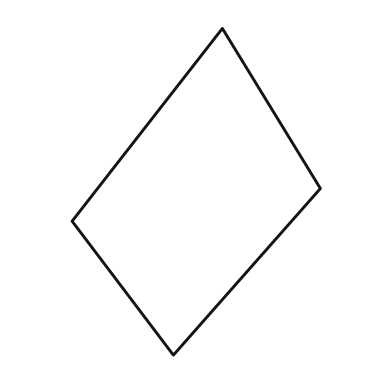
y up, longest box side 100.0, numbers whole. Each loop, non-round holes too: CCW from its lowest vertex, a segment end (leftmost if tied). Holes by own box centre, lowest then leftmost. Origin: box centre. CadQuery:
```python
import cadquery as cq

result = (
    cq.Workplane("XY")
    .moveTo(-7.0, -50.0)
    .lineTo(38.0, 1.0)
    .lineTo(8.0, 50.0)
    .lineTo(-38.0, -9.0)
    .close()
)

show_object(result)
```